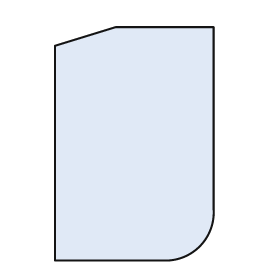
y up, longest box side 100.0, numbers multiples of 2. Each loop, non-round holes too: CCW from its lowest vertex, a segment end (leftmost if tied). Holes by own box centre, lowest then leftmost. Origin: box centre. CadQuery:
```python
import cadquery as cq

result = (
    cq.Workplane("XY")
    .moveTo(-34.0, -50.0)
    .lineTo(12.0, -50.0)
    .threePointArc((28.0, -44.0), (34.0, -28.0))
    .lineTo(34.0, 50.0)
    .lineTo(-8.0, 50.0)
    .lineTo(-34.0, 42.0)
    .close()
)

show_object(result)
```